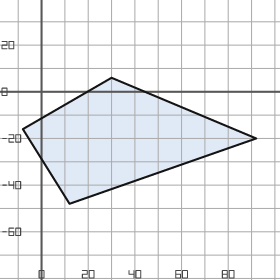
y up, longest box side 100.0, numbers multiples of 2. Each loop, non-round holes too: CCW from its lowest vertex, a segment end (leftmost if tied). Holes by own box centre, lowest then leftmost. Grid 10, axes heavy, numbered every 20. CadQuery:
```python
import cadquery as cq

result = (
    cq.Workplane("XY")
    .moveTo(12.0, -48.0)
    .lineTo(92.0, -20.0)
    .lineTo(30.0, 6.0)
    .lineTo(-8.0, -16.0)
    .close()
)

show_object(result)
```